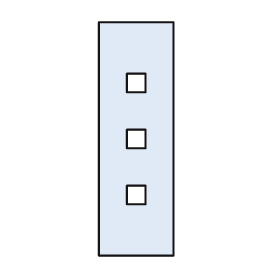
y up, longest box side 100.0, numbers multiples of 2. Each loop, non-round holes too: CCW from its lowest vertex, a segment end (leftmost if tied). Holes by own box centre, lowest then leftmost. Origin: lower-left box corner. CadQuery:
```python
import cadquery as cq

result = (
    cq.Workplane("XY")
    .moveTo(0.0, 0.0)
    .lineTo(32.0, 0.0)
    .lineTo(32.0, 100.0)
    .lineTo(0.0, 100.0)
    .close()
    .moveTo(12.0, 22.0)
    .lineTo(20.0, 22.0)
    .lineTo(20.0, 30.0)
    .lineTo(12.0, 30.0)
    .close()
    .moveTo(12.0, 46.0)
    .lineTo(20.0, 46.0)
    .lineTo(20.0, 54.0)
    .lineTo(12.0, 54.0)
    .close()
    .moveTo(12.0, 70.0)
    .lineTo(20.0, 70.0)
    .lineTo(20.0, 78.0)
    .lineTo(12.0, 78.0)
    .close()
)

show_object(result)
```